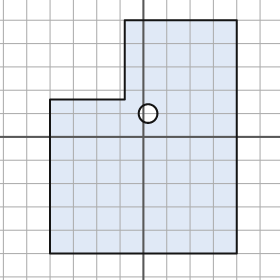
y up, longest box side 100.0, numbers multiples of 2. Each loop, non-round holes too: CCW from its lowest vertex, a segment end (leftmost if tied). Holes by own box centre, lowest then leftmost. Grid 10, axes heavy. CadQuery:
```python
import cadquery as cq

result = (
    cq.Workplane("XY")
    .moveTo(-40.0, -50.0)
    .lineTo(40.0, -50.0)
    .lineTo(40.0, 50.0)
    .lineTo(-8.0, 50.0)
    .lineTo(-8.0, 16.0)
    .lineTo(-40.0, 16.0)
    .close()
    .moveTo(2.0, 10.0)
    .circle(4.0)
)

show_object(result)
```